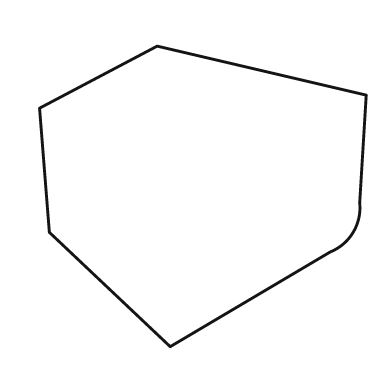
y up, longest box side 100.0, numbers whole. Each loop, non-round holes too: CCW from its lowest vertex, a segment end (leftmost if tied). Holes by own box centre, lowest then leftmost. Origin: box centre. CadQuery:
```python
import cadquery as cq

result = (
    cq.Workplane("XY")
    .moveTo(-10.0, -46.0)
    .lineTo(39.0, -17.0)
    .threePointArc((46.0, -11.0), (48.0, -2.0))
    .lineTo(50.0, 31.0)
    .lineTo(-14.0, 46.0)
    .lineTo(-50.0, 27.0)
    .lineTo(-47.0, -11.0)
    .close()
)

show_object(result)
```